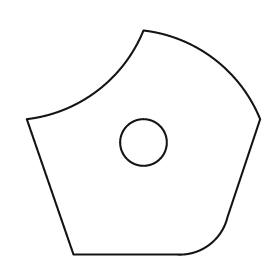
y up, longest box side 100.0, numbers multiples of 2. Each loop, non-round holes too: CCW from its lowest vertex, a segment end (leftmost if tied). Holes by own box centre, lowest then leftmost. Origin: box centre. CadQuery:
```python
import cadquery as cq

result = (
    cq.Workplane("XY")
    .moveTo(-30.0, -48.0)
    .lineTo(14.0, -48.0)
    .threePointArc((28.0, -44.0), (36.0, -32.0))
    .lineTo(50.0, 10.0)
    .threePointArc((30.0, 36.0), (0.0, 48.0))
    .threePointArc((-20.0, 22.0), (-50.0, 10.0))
    .close()
    .moveTo(0.0, 0.0)
    .circle(10.0)
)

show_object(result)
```